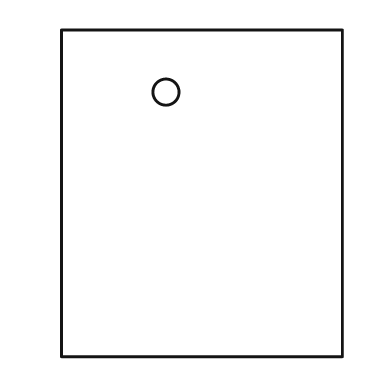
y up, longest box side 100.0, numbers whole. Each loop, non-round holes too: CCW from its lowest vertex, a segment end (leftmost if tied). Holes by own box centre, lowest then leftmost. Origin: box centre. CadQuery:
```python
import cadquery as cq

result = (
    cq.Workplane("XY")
    .moveTo(-43.0, -50.0)
    .lineTo(43.0, -50.0)
    .lineTo(43.0, 50.0)
    .lineTo(-43.0, 50.0)
    .close()
    .moveTo(-11.0, 31.0)
    .circle(4.0)
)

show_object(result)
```